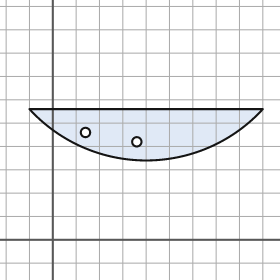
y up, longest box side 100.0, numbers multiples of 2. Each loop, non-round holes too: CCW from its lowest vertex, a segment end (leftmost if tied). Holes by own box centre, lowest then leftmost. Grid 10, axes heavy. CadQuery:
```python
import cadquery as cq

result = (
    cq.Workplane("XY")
    .moveTo(-10.0, 56.0)
    .threePointArc((40.0, 34.0), (90.0, 56.0))
    .close()
    .moveTo(36.0, 42.0)
    .circle(2.0)
    .moveTo(14.0, 46.0)
    .circle(2.0)
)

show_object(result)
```